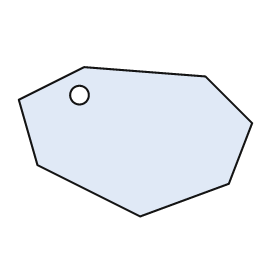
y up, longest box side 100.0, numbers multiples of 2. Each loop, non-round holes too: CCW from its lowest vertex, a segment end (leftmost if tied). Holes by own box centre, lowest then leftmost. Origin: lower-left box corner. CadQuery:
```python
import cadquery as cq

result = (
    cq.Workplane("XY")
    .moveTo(52.0, 0.0)
    .lineTo(90.0, 14.0)
    .lineTo(100.0, 40.0)
    .lineTo(80.0, 60.0)
    .lineTo(28.0, 64.0)
    .lineTo(0.0, 50.0)
    .lineTo(8.0, 22.0)
    .close()
    .moveTo(26.0, 52.0)
    .circle(4.0)
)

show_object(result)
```